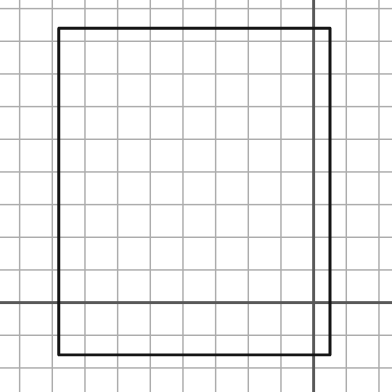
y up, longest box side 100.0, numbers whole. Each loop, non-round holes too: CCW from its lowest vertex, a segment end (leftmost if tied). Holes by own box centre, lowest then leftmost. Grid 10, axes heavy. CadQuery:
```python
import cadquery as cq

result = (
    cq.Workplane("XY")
    .moveTo(-78.0, -16.0)
    .lineTo(5.0, -16.0)
    .lineTo(5.0, 84.0)
    .lineTo(-78.0, 84.0)
    .close()
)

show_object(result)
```